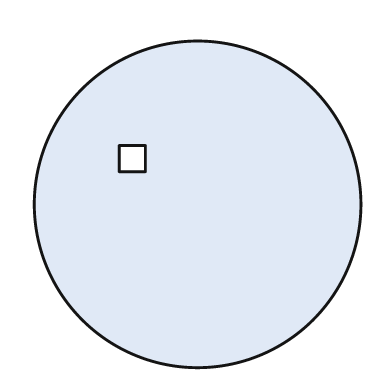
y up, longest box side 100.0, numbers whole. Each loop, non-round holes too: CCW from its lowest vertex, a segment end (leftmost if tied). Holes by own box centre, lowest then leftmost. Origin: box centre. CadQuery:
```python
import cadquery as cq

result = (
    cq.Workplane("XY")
    .moveTo(0.0, 0.0)
    .circle(50.0)
    .moveTo(-24.0, 10.0)
    .lineTo(-16.0, 10.0)
    .lineTo(-16.0, 18.0)
    .lineTo(-24.0, 18.0)
    .close()
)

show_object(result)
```